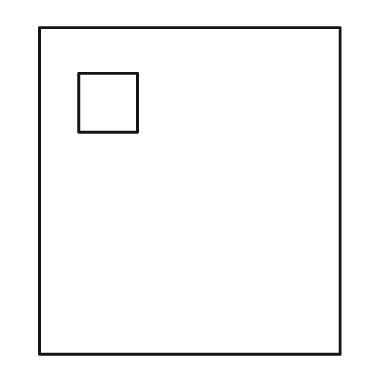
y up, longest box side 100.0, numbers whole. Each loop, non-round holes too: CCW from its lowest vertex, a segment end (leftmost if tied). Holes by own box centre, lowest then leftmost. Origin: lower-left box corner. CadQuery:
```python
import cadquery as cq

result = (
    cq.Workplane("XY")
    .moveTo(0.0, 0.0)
    .lineTo(92.0, 0.0)
    .lineTo(92.0, 100.0)
    .lineTo(0.0, 100.0)
    .close()
    .moveTo(12.0, 68.0)
    .lineTo(30.0, 68.0)
    .lineTo(30.0, 86.0)
    .lineTo(12.0, 86.0)
    .close()
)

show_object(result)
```